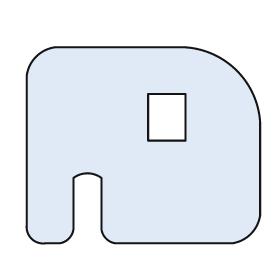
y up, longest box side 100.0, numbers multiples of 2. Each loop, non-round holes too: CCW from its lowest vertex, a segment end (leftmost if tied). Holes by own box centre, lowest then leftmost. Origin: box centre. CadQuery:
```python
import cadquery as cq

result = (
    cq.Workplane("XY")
    .moveTo(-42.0, -42.0)
    .lineTo(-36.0, -42.0)
    .threePointArc((-32.0, -40.0), (-30.0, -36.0))
    .lineTo(-30.0, -14.0)
    .threePointArc((-24.0, -12.0), (-18.0, -14.0))
    .lineTo(-18.0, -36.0)
    .threePointArc((-16.0, -40.0), (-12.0, -42.0))
    .lineTo(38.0, -42.0)
    .threePointArc((46.0, -38.0), (50.0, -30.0))
    .lineTo(50.0, 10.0)
    .threePointArc((40.0, 32.0), (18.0, 42.0))
    .lineTo(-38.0, 42.0)
    .threePointArc((-46.0, 38.0), (-50.0, 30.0))
    .lineTo(-50.0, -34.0)
    .threePointArc((-48.0, -40.0), (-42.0, -42.0))
    .close()
    .moveTo(2.0, 2.0)
    .lineTo(18.0, 2.0)
    .lineTo(18.0, 22.0)
    .lineTo(2.0, 22.0)
    .close()
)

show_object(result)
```